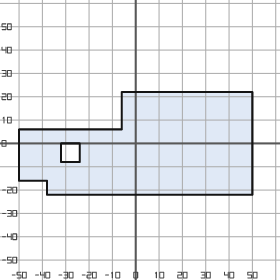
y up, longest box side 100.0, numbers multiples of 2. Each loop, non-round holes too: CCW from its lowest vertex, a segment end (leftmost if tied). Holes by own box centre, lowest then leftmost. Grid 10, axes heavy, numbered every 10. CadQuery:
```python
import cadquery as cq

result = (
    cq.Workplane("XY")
    .moveTo(-38.0, -22.0)
    .lineTo(50.0, -22.0)
    .lineTo(50.0, 22.0)
    .lineTo(-6.0, 22.0)
    .lineTo(-6.0, 6.0)
    .lineTo(-50.0, 6.0)
    .lineTo(-50.0, -16.0)
    .lineTo(-38.0, -16.0)
    .close()
    .moveTo(-32.0, -8.0)
    .lineTo(-24.0, -8.0)
    .lineTo(-24.0, 0.0)
    .lineTo(-32.0, 0.0)
    .close()
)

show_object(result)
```